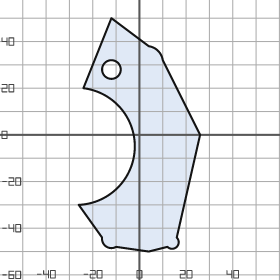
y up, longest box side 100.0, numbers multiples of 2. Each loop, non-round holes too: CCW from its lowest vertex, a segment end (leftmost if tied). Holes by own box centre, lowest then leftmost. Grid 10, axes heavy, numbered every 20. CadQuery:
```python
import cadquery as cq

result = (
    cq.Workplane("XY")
    .moveTo(4.0, -50.0)
    .lineTo(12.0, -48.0)
    .threePointArc((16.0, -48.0), (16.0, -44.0))
    .lineTo(26.0, 0.0)
    .lineTo(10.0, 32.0)
    .threePointArc((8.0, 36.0), (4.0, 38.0))
    .lineTo(-12.0, 50.0)
    .lineTo(-24.0, 20.0)
    .threePointArc((-2.0, -6.0), (-26.0, -30.0))
    .lineTo(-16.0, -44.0)
    .threePointArc((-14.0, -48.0), (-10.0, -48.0))
    .close()
    .moveTo(-12.0, 28.0)
    .circle(4.0)
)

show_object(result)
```